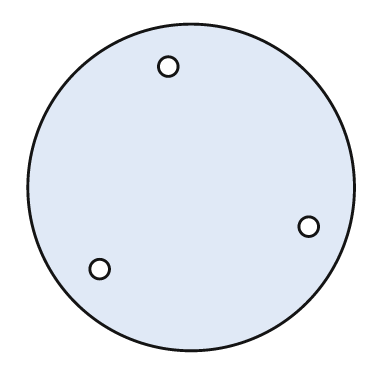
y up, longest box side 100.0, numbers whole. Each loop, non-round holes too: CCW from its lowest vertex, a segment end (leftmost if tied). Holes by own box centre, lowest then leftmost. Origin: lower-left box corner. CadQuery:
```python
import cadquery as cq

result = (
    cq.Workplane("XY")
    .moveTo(50.0, 50.0)
    .circle(50.0)
    .moveTo(22.0, 25.0)
    .circle(3.0)
    .moveTo(86.0, 38.0)
    .circle(3.0)
    .moveTo(43.0, 87.0)
    .circle(3.0)
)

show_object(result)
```